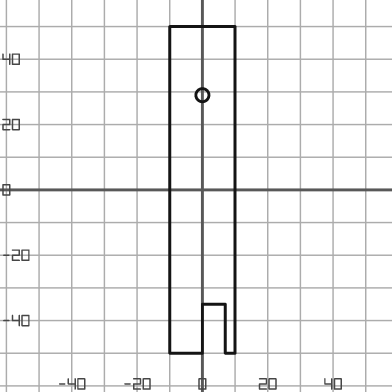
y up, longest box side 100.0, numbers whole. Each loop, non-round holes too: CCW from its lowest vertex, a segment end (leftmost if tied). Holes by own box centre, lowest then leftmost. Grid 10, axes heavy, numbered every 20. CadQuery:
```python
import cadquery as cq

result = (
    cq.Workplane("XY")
    .moveTo(-10.0, -50.0)
    .lineTo(0.0, -50.0)
    .lineTo(0.0, -35.0)
    .lineTo(7.0, -35.0)
    .lineTo(7.0, -50.0)
    .lineTo(10.0, -50.0)
    .lineTo(10.0, 50.0)
    .lineTo(-10.0, 50.0)
    .close()
    .moveTo(0.0, 29.0)
    .circle(2.0)
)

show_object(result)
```